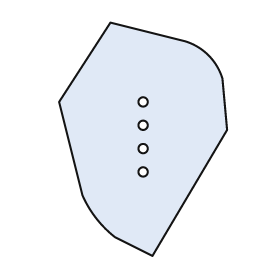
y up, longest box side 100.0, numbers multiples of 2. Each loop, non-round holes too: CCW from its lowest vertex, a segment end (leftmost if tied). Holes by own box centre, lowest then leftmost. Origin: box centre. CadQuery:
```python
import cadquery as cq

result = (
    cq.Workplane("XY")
    .moveTo(4.0, -50.0)
    .lineTo(36.0, 4.0)
    .lineTo(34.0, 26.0)
    .threePointArc((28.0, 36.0), (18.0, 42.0))
    .lineTo(-14.0, 50.0)
    .lineTo(-36.0, 16.0)
    .lineTo(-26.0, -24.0)
    .threePointArc((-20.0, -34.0), (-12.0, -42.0))
    .close()
    .moveTo(0.0, -14.0)
    .circle(2.0)
    .moveTo(0.0, -4.0)
    .circle(2.0)
    .moveTo(0.0, 6.0)
    .circle(2.0)
    .moveTo(0.0, 16.0)
    .circle(2.0)
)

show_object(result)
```